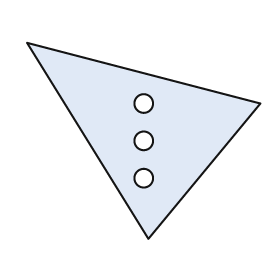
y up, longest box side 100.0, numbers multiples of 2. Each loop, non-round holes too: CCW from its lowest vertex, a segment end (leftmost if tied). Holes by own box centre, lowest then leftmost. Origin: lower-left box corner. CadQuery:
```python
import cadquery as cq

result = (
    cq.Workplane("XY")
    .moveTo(52.0, 0.0)
    .lineTo(100.0, 58.0)
    .lineTo(0.0, 84.0)
    .close()
    .moveTo(50.0, 26.0)
    .circle(4.0)
    .moveTo(50.0, 42.0)
    .circle(4.0)
    .moveTo(50.0, 58.0)
    .circle(4.0)
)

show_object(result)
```